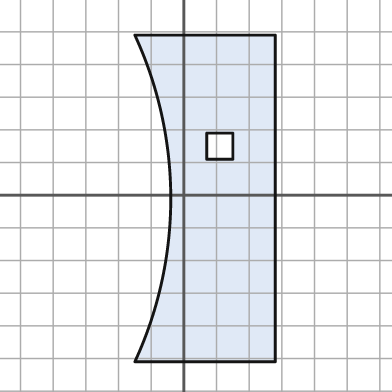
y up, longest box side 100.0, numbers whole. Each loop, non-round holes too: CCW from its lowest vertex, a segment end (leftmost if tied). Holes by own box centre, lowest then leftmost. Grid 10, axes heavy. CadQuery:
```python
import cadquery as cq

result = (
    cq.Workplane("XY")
    .moveTo(-15.0, -51.0)
    .lineTo(28.0, -51.0)
    .lineTo(28.0, 49.0)
    .lineTo(-15.0, 49.0)
    .threePointArc((-4.0, -1.0), (-15.0, -51.0))
    .close()
    .moveTo(7.0, 11.0)
    .lineTo(15.0, 11.0)
    .lineTo(15.0, 19.0)
    .lineTo(7.0, 19.0)
    .close()
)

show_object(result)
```